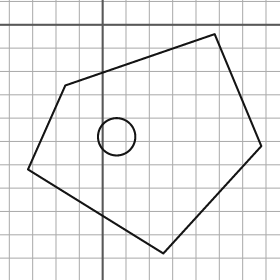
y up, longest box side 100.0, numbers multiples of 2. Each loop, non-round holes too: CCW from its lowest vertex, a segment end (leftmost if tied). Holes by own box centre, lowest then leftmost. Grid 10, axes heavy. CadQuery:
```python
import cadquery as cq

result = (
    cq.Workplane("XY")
    .moveTo(26.0, -98.0)
    .lineTo(68.0, -52.0)
    .lineTo(48.0, -4.0)
    .lineTo(-16.0, -26.0)
    .lineTo(-32.0, -62.0)
    .close()
    .moveTo(6.0, -48.0)
    .circle(8.0)
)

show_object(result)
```